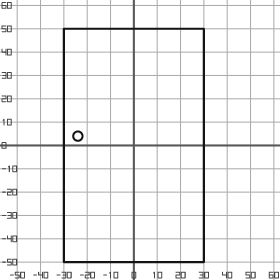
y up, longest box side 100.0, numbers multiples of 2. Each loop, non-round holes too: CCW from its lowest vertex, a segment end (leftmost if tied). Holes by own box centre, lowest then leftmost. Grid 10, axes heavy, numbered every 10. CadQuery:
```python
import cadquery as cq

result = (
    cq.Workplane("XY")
    .moveTo(-30.0, -50.0)
    .lineTo(30.0, -50.0)
    .lineTo(30.0, 50.0)
    .lineTo(-30.0, 50.0)
    .close()
    .moveTo(-24.0, 4.0)
    .circle(2.0)
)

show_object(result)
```